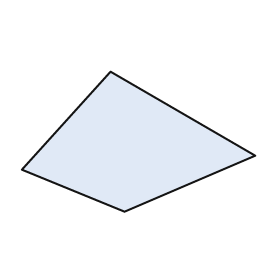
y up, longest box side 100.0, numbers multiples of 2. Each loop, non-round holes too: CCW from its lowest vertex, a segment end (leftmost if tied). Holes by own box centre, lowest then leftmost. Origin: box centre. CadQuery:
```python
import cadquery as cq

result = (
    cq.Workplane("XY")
    .moveTo(-6.0, -30.0)
    .lineTo(50.0, -6.0)
    .lineTo(-12.0, 30.0)
    .lineTo(-50.0, -12.0)
    .close()
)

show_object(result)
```